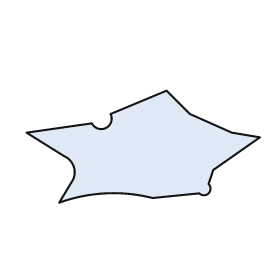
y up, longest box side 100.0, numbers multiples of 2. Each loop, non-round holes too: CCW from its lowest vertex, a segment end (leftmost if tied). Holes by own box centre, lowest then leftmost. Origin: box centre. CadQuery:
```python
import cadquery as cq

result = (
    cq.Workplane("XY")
    .moveTo(-36.0, -24.0)
    .threePointArc((-16.0, -20.0), (4.0, -22.0))
    .lineTo(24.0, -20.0)
    .threePointArc((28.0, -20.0), (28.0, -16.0))
    .lineTo(30.0, -10.0)
    .lineTo(50.0, 4.0)
    .lineTo(38.0, 6.0)
    .lineTo(20.0, 14.0)
    .lineTo(10.0, 24.0)
    .lineTo(-14.0, 14.0)
    .threePointArc((-16.0, 8.0), (-22.0, 10.0))
    .lineTo(-50.0, 6.0)
    .lineTo(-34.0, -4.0)
    .threePointArc((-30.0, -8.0), (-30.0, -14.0))
    .close()
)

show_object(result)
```